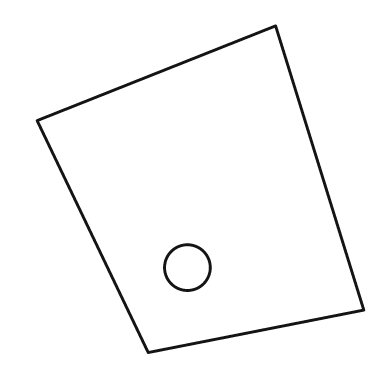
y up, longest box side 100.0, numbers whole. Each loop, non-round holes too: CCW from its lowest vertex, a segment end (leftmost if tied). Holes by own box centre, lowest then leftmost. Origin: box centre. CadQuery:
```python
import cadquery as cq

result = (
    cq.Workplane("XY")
    .moveTo(-16.0, -50.0)
    .lineTo(50.0, -37.0)
    .lineTo(23.0, 50.0)
    .lineTo(-50.0, 21.0)
    .close()
    .moveTo(-4.0, -24.0)
    .circle(7.0)
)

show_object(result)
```